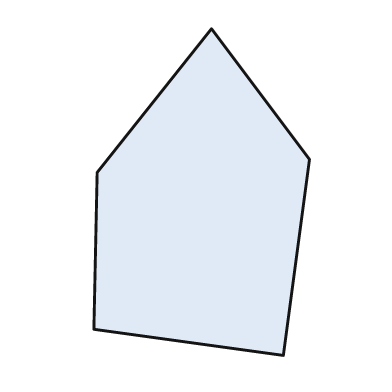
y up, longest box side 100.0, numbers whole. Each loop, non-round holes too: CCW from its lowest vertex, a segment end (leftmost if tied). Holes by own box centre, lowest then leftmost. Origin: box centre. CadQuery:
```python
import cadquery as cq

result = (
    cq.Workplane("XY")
    .moveTo(25.0, -50.0)
    .lineTo(33.0, 10.0)
    .lineTo(3.0, 50.0)
    .lineTo(-32.0, 6.0)
    .lineTo(-33.0, -42.0)
    .close()
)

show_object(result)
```